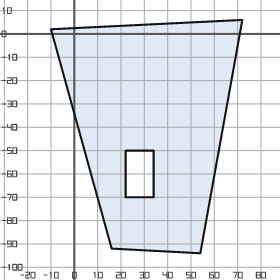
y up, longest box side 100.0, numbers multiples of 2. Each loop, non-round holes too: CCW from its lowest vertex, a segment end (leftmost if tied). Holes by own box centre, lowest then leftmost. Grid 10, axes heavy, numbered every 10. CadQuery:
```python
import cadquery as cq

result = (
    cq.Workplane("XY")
    .moveTo(54.0, -94.0)
    .lineTo(72.0, 6.0)
    .lineTo(-10.0, 2.0)
    .lineTo(16.0, -92.0)
    .close()
    .moveTo(22.0, -70.0)
    .lineTo(34.0, -70.0)
    .lineTo(34.0, -50.0)
    .lineTo(22.0, -50.0)
    .close()
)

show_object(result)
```